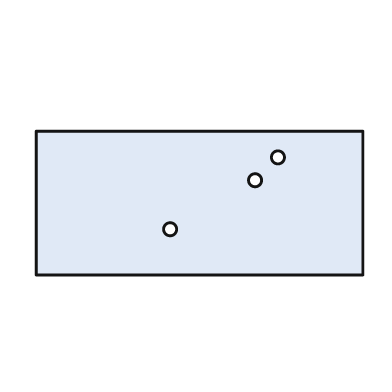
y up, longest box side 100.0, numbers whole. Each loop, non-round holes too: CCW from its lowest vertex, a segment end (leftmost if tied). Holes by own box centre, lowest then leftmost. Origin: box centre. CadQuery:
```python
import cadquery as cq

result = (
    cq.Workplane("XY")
    .moveTo(-50.0, -22.0)
    .lineTo(50.0, -22.0)
    .lineTo(50.0, 22.0)
    .lineTo(-50.0, 22.0)
    .close()
    .moveTo(-9.0, -8.0)
    .circle(2.0)
    .moveTo(17.0, 7.0)
    .circle(2.0)
    .moveTo(24.0, 14.0)
    .circle(2.0)
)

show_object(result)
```